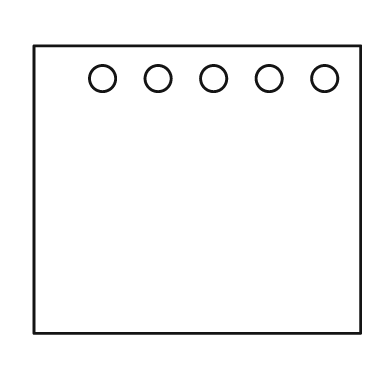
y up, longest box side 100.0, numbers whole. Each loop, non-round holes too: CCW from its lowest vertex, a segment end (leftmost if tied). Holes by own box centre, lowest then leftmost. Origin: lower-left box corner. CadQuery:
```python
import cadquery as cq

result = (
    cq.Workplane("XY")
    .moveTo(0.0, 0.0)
    .lineTo(100.0, 0.0)
    .lineTo(100.0, 88.0)
    .lineTo(0.0, 88.0)
    .close()
    .moveTo(21.0, 78.0)
    .circle(4.0)
    .moveTo(38.0, 78.0)
    .circle(4.0)
    .moveTo(55.0, 78.0)
    .circle(4.0)
    .moveTo(72.0, 78.0)
    .circle(4.0)
    .moveTo(89.0, 78.0)
    .circle(4.0)
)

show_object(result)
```